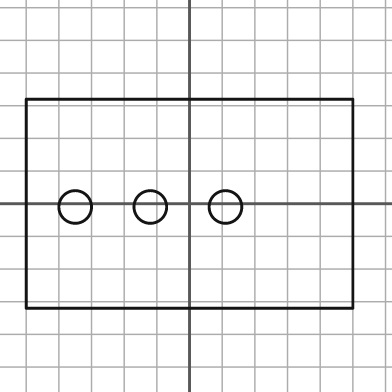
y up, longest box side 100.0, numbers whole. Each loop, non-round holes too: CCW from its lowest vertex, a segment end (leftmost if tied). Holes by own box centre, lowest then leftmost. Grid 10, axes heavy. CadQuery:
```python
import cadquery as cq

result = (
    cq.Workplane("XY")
    .moveTo(-50.0, -32.0)
    .lineTo(50.0, -32.0)
    .lineTo(50.0, 32.0)
    .lineTo(-50.0, 32.0)
    .close()
    .moveTo(-35.0, -1.0)
    .circle(5.0)
    .moveTo(-12.0, -1.0)
    .circle(5.0)
    .moveTo(11.0, -1.0)
    .circle(5.0)
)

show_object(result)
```